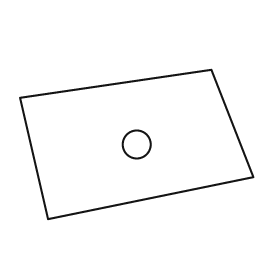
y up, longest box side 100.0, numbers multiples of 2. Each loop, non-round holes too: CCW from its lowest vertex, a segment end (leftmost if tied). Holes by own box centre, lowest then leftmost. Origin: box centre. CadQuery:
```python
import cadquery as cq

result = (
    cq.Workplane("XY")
    .moveTo(-38.0, -32.0)
    .lineTo(50.0, -14.0)
    .lineTo(32.0, 32.0)
    .lineTo(-50.0, 20.0)
    .close()
    .moveTo(0.0, 0.0)
    .circle(6.0)
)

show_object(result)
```